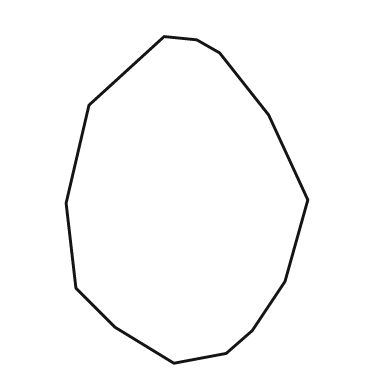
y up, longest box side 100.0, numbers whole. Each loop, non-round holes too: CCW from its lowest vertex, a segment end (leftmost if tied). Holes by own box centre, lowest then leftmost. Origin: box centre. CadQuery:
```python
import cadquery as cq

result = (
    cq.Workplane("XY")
    .moveTo(-4.0, -50.0)
    .lineTo(12.0, -47.0)
    .lineTo(20.0, -40.0)
    .lineTo(30.0, -25.0)
    .lineTo(37.0, 0.0)
    .lineTo(25.0, 26.0)
    .lineTo(10.0, 45.0)
    .lineTo(3.0, 49.0)
    .lineTo(-7.0, 50.0)
    .lineTo(-30.0, 29.0)
    .lineTo(-37.0, -1.0)
    .lineTo(-34.0, -27.0)
    .lineTo(-22.0, -39.0)
    .close()
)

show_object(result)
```